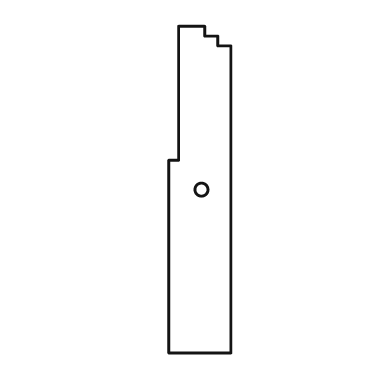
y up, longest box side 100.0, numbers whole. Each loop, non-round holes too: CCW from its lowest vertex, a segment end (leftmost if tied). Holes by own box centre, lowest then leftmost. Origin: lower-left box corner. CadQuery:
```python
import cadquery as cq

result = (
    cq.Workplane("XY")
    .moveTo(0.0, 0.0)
    .lineTo(19.0, 0.0)
    .lineTo(19.0, 94.0)
    .lineTo(15.0, 94.0)
    .lineTo(15.0, 97.0)
    .lineTo(11.0, 97.0)
    .lineTo(11.0, 100.0)
    .lineTo(3.0, 100.0)
    .lineTo(3.0, 59.0)
    .lineTo(0.0, 59.0)
    .close()
    .moveTo(10.0, 50.0)
    .circle(2.0)
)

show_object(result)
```